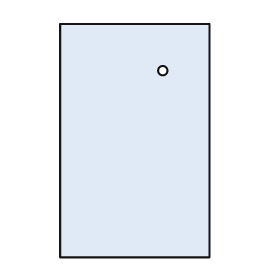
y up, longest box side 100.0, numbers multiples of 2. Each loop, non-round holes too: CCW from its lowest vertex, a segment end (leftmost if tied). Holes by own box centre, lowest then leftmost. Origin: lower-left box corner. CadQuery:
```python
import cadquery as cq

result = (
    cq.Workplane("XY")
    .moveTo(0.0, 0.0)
    .lineTo(64.0, 0.0)
    .lineTo(64.0, 100.0)
    .lineTo(0.0, 100.0)
    .close()
    .moveTo(44.0, 80.0)
    .circle(2.0)
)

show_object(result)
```